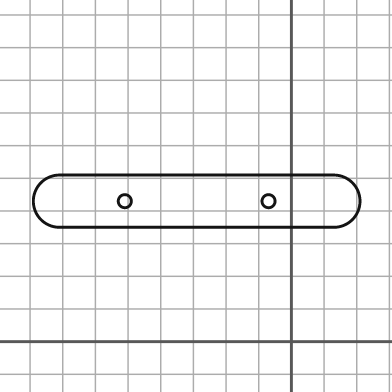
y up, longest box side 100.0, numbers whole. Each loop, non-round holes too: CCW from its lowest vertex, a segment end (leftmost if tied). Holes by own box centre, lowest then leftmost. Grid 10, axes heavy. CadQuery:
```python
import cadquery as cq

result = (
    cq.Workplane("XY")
    .moveTo(-71.0, 35.0)
    .lineTo(13.0, 35.0)
    .threePointArc((21.0, 43.0), (13.0, 51.0))
    .lineTo(-71.0, 51.0)
    .threePointArc((-79.0, 43.0), (-71.0, 35.0))
    .close()
    .moveTo(-51.0, 43.0)
    .circle(2.0)
    .moveTo(-7.0, 43.0)
    .circle(2.0)
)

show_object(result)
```